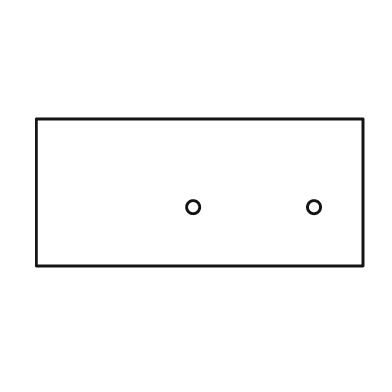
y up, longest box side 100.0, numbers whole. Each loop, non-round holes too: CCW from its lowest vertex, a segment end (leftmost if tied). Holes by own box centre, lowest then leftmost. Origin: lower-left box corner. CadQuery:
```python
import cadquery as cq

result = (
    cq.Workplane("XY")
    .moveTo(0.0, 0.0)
    .lineTo(100.0, 0.0)
    .lineTo(100.0, 45.0)
    .lineTo(0.0, 45.0)
    .close()
    .moveTo(48.0, 18.0)
    .circle(2.0)
    .moveTo(85.0, 18.0)
    .circle(2.0)
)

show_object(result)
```